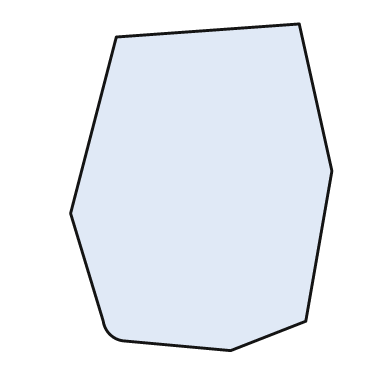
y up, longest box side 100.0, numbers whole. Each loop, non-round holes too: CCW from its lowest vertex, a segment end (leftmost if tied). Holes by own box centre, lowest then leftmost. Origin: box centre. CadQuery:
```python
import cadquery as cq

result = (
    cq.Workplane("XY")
    .moveTo(9.0, -50.0)
    .lineTo(32.0, -41.0)
    .lineTo(40.0, 5.0)
    .lineTo(30.0, 50.0)
    .lineTo(-26.0, 46.0)
    .lineTo(-40.0, -8.0)
    .lineTo(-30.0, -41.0)
    .threePointArc((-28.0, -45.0), (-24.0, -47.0))
    .close()
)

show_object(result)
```